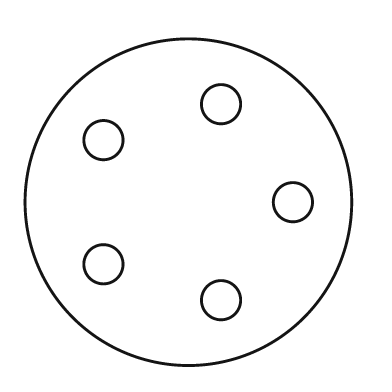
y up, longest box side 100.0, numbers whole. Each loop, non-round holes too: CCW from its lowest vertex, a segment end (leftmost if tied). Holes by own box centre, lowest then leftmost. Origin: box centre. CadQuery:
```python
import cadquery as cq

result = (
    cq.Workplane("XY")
    .moveTo(0.0, 0.0)
    .circle(50.0)
    .moveTo(10.0, -30.0)
    .circle(6.0)
    .moveTo(-26.0, -19.0)
    .circle(6.0)
    .moveTo(32.0, 0.0)
    .circle(6.0)
    .moveTo(-26.0, 19.0)
    .circle(6.0)
    .moveTo(10.0, 30.0)
    .circle(6.0)
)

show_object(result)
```